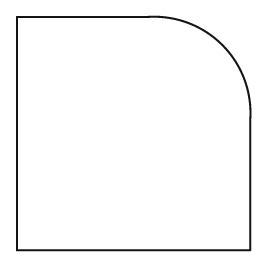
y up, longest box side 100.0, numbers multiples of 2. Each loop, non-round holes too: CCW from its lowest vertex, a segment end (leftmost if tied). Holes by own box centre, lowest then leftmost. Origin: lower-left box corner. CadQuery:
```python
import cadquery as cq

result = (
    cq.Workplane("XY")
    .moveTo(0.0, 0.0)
    .lineTo(100.0, 0.0)
    .lineTo(100.0, 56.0)
    .threePointArc((88.0, 88.0), (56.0, 100.0))
    .lineTo(0.0, 100.0)
    .close()
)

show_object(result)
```